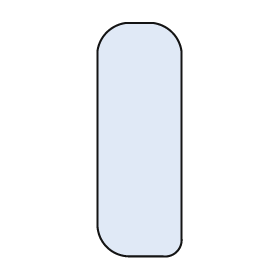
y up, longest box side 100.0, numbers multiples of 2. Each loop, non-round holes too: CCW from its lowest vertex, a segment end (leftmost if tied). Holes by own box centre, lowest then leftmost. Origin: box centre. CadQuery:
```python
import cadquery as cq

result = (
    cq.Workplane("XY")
    .moveTo(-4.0, -50.0)
    .lineTo(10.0, -50.0)
    .threePointArc((16.0, -48.0), (18.0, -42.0))
    .lineTo(18.0, 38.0)
    .threePointArc((14.0, 46.0), (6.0, 50.0))
    .lineTo(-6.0, 50.0)
    .threePointArc((-14.0, 46.0), (-18.0, 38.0))
    .lineTo(-18.0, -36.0)
    .threePointArc((-14.0, -46.0), (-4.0, -50.0))
    .close()
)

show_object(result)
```